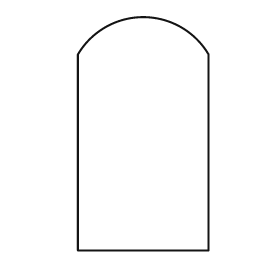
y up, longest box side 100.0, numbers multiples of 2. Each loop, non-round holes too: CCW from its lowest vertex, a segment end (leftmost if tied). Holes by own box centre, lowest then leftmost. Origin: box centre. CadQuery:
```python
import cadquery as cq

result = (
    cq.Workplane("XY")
    .moveTo(-28.0, -50.0)
    .lineTo(28.0, -50.0)
    .lineTo(28.0, 34.0)
    .threePointArc((0.0, 50.0), (-28.0, 34.0))
    .close()
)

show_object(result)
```